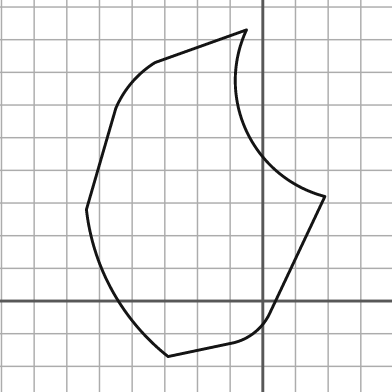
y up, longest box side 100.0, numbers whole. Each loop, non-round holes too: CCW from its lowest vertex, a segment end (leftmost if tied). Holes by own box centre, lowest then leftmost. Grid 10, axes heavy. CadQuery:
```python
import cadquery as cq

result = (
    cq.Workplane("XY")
    .moveTo(-29.0, -17.0)
    .lineTo(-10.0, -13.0)
    .threePointArc((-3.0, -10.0), (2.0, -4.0))
    .lineTo(19.0, 32.0)
    .threePointArc((-5.0, 52.0), (-5.0, 83.0))
    .lineTo(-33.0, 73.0)
    .threePointArc((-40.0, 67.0), (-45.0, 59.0))
    .lineTo(-54.0, 28.0)
    .threePointArc((-46.0, 3.0), (-29.0, -17.0))
    .close()
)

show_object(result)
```